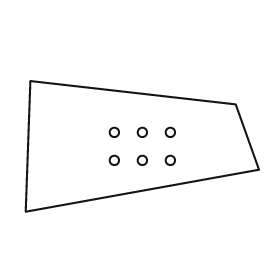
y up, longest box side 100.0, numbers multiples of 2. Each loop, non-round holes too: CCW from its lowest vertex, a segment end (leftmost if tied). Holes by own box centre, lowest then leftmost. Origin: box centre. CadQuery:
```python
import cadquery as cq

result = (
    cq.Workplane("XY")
    .moveTo(-50.0, -28.0)
    .lineTo(50.0, -10.0)
    .lineTo(40.0, 18.0)
    .lineTo(-48.0, 28.0)
    .close()
    .moveTo(-12.0, -6.0)
    .circle(2.0)
    .moveTo(0.0, -6.0)
    .circle(2.0)
    .moveTo(12.0, -6.0)
    .circle(2.0)
    .moveTo(-12.0, 6.0)
    .circle(2.0)
    .moveTo(0.0, 6.0)
    .circle(2.0)
    .moveTo(12.0, 6.0)
    .circle(2.0)
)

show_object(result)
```